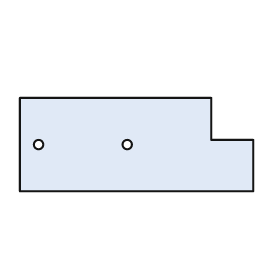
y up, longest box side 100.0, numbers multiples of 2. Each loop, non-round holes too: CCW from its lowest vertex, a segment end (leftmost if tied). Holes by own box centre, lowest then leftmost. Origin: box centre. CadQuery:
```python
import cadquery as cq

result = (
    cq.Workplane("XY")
    .moveTo(-50.0, -20.0)
    .lineTo(50.0, -20.0)
    .lineTo(50.0, 2.0)
    .lineTo(32.0, 2.0)
    .lineTo(32.0, 20.0)
    .lineTo(-50.0, 20.0)
    .close()
    .moveTo(-42.0, 0.0)
    .circle(2.0)
    .moveTo(-4.0, 0.0)
    .circle(2.0)
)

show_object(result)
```